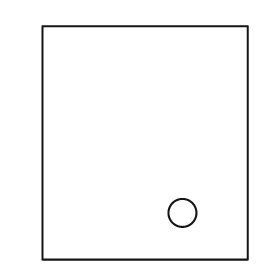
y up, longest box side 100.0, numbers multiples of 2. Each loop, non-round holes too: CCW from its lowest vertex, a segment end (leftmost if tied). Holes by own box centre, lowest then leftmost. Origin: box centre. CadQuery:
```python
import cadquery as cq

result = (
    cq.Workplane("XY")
    .moveTo(-44.0, -50.0)
    .lineTo(44.0, -50.0)
    .lineTo(44.0, 50.0)
    .lineTo(-44.0, 50.0)
    .close()
    .moveTo(16.0, -30.0)
    .circle(6.0)
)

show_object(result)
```